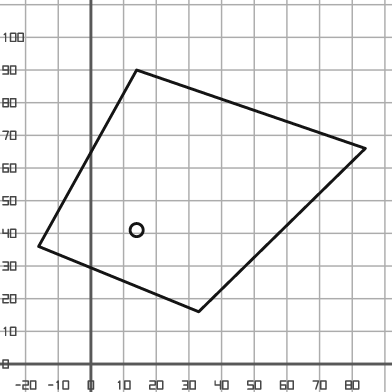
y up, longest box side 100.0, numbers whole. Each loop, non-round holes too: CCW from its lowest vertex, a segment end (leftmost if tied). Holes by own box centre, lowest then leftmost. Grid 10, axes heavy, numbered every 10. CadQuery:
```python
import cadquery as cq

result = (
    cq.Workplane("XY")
    .moveTo(33.0, 16.0)
    .lineTo(84.0, 66.0)
    .lineTo(14.0, 90.0)
    .lineTo(-16.0, 36.0)
    .close()
    .moveTo(14.0, 41.0)
    .circle(2.0)
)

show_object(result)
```